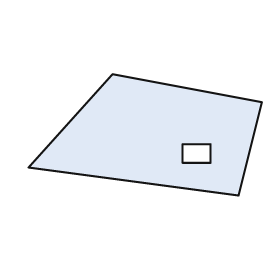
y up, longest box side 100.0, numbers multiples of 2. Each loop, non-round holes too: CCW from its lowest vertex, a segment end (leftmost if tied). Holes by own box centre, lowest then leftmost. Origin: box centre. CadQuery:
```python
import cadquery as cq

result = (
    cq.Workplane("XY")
    .moveTo(40.0, -26.0)
    .lineTo(50.0, 14.0)
    .lineTo(-14.0, 26.0)
    .lineTo(-50.0, -14.0)
    .close()
    .moveTo(16.0, -12.0)
    .lineTo(28.0, -12.0)
    .lineTo(28.0, -4.0)
    .lineTo(16.0, -4.0)
    .close()
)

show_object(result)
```